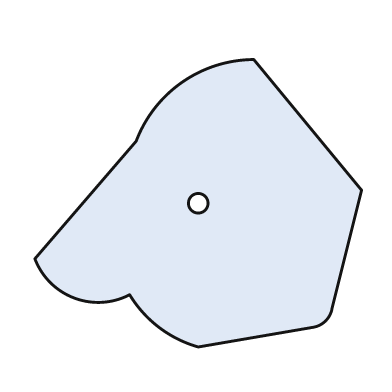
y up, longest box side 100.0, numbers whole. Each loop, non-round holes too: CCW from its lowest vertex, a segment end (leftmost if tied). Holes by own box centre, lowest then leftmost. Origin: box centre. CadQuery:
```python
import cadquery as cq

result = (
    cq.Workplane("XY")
    .moveTo(0.0, -44.0)
    .lineTo(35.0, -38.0)
    .threePointArc((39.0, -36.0), (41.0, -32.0))
    .lineTo(50.0, 4.0)
    .lineTo(17.0, 44.0)
    .threePointArc((-5.0, 37.0), (-19.0, 19.0))
    .lineTo(-50.0, -17.0)
    .threePointArc((-38.0, -29.0), (-21.0, -28.0))
    .threePointArc((-12.0, -38.0), (0.0, -44.0))
    .close()
    .moveTo(0.0, 0.0)
    .circle(3.0)
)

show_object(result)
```